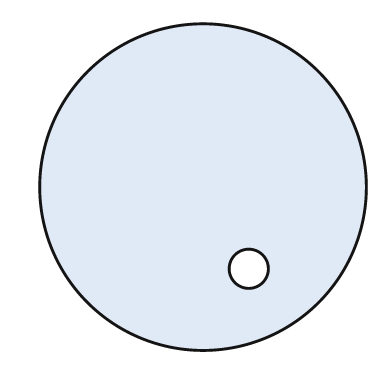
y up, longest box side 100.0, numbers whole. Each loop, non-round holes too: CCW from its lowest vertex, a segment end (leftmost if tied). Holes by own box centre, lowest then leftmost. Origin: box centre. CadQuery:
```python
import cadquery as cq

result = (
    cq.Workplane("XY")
    .moveTo(0.0, 0.0)
    .circle(50.0)
    .moveTo(14.0, -25.0)
    .circle(6.0)
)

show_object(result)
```